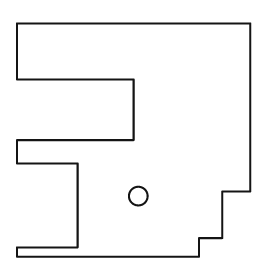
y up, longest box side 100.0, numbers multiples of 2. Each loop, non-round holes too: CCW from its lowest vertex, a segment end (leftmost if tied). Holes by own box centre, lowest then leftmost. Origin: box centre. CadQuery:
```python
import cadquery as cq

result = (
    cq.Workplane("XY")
    .moveTo(-50.0, -50.0)
    .lineTo(28.0, -50.0)
    .lineTo(28.0, -42.0)
    .lineTo(38.0, -42.0)
    .lineTo(38.0, -22.0)
    .lineTo(50.0, -22.0)
    .lineTo(50.0, 50.0)
    .lineTo(-50.0, 50.0)
    .lineTo(-50.0, 26.0)
    .lineTo(0.0, 26.0)
    .lineTo(0.0, 0.0)
    .lineTo(-50.0, 0.0)
    .lineTo(-50.0, -10.0)
    .lineTo(-24.0, -10.0)
    .lineTo(-24.0, -46.0)
    .lineTo(-50.0, -46.0)
    .close()
    .moveTo(2.0, -24.0)
    .circle(4.0)
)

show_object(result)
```